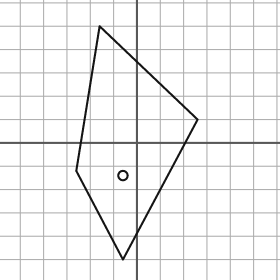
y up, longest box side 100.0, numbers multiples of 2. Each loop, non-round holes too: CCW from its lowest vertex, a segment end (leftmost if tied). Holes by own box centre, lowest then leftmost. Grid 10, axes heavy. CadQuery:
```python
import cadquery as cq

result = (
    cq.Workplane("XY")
    .moveTo(-6.0, -50.0)
    .lineTo(26.0, 10.0)
    .lineTo(-16.0, 50.0)
    .lineTo(-26.0, -12.0)
    .close()
    .moveTo(-6.0, -14.0)
    .circle(2.0)
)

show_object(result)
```